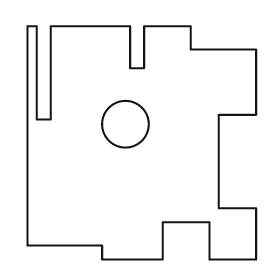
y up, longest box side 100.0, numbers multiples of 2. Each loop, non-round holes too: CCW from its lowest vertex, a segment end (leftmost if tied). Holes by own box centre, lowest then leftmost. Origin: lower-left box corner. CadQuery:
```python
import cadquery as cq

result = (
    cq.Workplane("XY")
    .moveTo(32.0, 0.0)
    .lineTo(58.0, 0.0)
    .lineTo(58.0, 16.0)
    .lineTo(78.0, 16.0)
    .lineTo(78.0, 0.0)
    .lineTo(98.0, 0.0)
    .lineTo(98.0, 22.0)
    .lineTo(82.0, 22.0)
    .lineTo(82.0, 62.0)
    .lineTo(98.0, 62.0)
    .lineTo(98.0, 90.0)
    .lineTo(70.0, 90.0)
    .lineTo(70.0, 100.0)
    .lineTo(50.0, 100.0)
    .lineTo(50.0, 82.0)
    .lineTo(44.0, 82.0)
    .lineTo(44.0, 100.0)
    .lineTo(10.0, 100.0)
    .lineTo(10.0, 60.0)
    .lineTo(4.0, 60.0)
    .lineTo(4.0, 100.0)
    .lineTo(0.0, 100.0)
    .lineTo(0.0, 6.0)
    .lineTo(32.0, 6.0)
    .close()
    .moveTo(42.0, 58.0)
    .circle(10.0)
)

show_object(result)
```